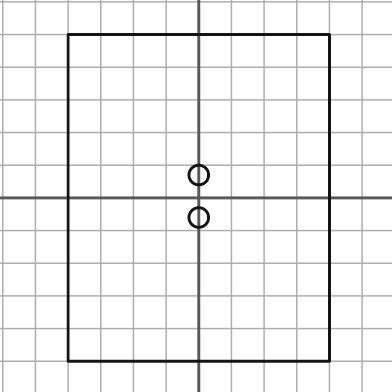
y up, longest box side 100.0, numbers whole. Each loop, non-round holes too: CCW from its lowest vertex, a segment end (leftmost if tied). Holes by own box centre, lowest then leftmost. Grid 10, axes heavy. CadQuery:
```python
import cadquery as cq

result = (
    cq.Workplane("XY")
    .moveTo(-40.0, -50.0)
    .lineTo(40.0, -50.0)
    .lineTo(40.0, 50.0)
    .lineTo(-40.0, 50.0)
    .close()
    .moveTo(0.0, -6.0)
    .circle(3.0)
    .moveTo(0.0, 7.0)
    .circle(3.0)
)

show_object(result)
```